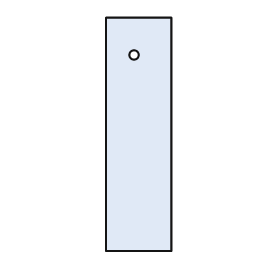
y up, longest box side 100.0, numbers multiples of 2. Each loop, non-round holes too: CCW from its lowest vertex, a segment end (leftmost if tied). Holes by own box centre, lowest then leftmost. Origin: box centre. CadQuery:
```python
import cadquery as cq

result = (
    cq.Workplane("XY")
    .moveTo(-14.0, -50.0)
    .lineTo(14.0, -50.0)
    .lineTo(14.0, 50.0)
    .lineTo(-14.0, 50.0)
    .close()
    .moveTo(-2.0, 34.0)
    .circle(2.0)
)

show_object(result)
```